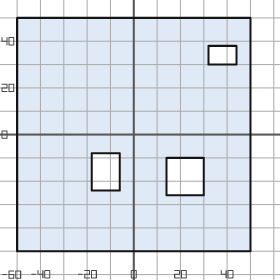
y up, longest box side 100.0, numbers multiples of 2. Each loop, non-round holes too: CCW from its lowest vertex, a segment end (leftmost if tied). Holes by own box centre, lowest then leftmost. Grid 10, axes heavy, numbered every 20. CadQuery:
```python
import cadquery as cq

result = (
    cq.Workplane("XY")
    .moveTo(-50.0, -50.0)
    .lineTo(50.0, -50.0)
    .lineTo(50.0, 50.0)
    .lineTo(-50.0, 50.0)
    .close()
    .moveTo(14.0, -26.0)
    .lineTo(30.0, -26.0)
    .lineTo(30.0, -10.0)
    .lineTo(14.0, -10.0)
    .close()
    .moveTo(-18.0, -24.0)
    .lineTo(-6.0, -24.0)
    .lineTo(-6.0, -8.0)
    .lineTo(-18.0, -8.0)
    .close()
    .moveTo(32.0, 30.0)
    .lineTo(44.0, 30.0)
    .lineTo(44.0, 38.0)
    .lineTo(32.0, 38.0)
    .close()
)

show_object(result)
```